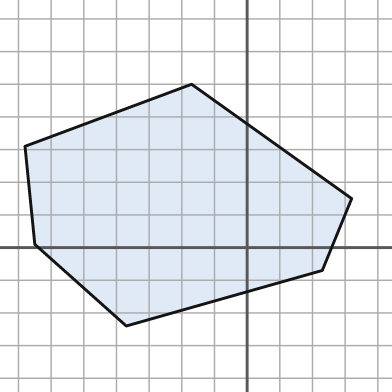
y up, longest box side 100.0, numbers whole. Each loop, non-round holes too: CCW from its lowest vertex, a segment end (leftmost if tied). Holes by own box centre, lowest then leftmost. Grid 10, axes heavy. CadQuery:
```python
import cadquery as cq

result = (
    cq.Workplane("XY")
    .moveTo(-37.0, -24.0)
    .lineTo(23.0, -7.0)
    .lineTo(32.0, 15.0)
    .lineTo(-17.0, 50.0)
    .lineTo(-68.0, 31.0)
    .lineTo(-65.0, 1.0)
    .close()
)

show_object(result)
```